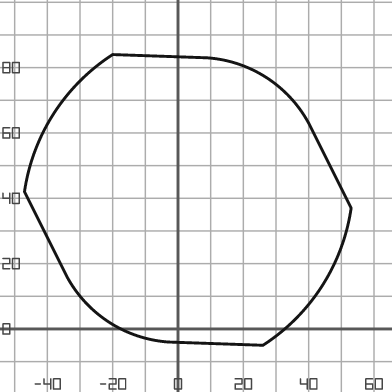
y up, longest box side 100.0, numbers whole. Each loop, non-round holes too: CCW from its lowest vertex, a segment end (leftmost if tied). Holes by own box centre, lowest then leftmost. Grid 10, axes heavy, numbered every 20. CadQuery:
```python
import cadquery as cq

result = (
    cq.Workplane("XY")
    .moveTo(26.0, -5.0)
    .threePointArc((44.0, 13.0), (53.0, 37.0))
    .lineTo(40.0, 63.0)
    .threePointArc((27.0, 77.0), (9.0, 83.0))
    .lineTo(-20.0, 84.0)
    .threePointArc((-38.0, 66.0), (-47.0, 42.0))
    .lineTo(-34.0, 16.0)
    .threePointArc((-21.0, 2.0), (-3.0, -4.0))
    .close()
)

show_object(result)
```